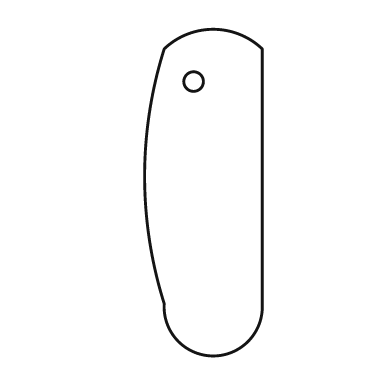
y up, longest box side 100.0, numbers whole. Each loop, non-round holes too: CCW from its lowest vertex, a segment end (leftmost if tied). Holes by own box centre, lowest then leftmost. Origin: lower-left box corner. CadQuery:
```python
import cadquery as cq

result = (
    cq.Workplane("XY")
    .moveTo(6.0, 16.0)
    .threePointArc((21.0, 0.0), (36.0, 16.0))
    .lineTo(36.0, 94.0)
    .threePointArc((21.0, 100.0), (6.0, 94.0))
    .threePointArc((0.0, 55.0), (6.0, 16.0))
    .close()
    .moveTo(15.0, 84.0)
    .circle(3.0)
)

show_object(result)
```